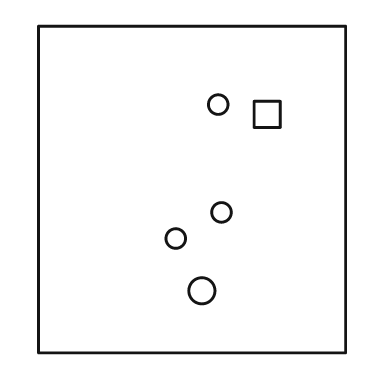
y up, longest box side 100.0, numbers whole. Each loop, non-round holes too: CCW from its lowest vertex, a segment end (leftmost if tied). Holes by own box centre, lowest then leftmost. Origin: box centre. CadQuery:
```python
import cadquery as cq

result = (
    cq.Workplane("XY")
    .moveTo(-47.0, -50.0)
    .lineTo(47.0, -50.0)
    .lineTo(47.0, 50.0)
    .lineTo(-47.0, 50.0)
    .close()
    .moveTo(3.0, -31.0)
    .circle(4.0)
    .moveTo(-5.0, -15.0)
    .circle(3.0)
    .moveTo(9.0, -7.0)
    .circle(3.0)
    .moveTo(19.0, 19.0)
    .lineTo(27.0, 19.0)
    .lineTo(27.0, 27.0)
    .lineTo(19.0, 27.0)
    .close()
    .moveTo(8.0, 26.0)
    .circle(3.0)
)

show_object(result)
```